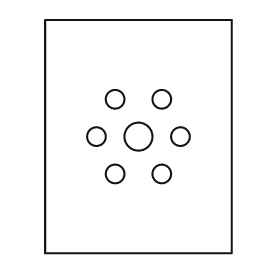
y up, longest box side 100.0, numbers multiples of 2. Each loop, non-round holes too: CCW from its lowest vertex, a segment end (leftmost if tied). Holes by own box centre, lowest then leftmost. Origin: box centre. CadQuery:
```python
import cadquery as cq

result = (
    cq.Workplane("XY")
    .moveTo(-40.0, -50.0)
    .lineTo(40.0, -50.0)
    .lineTo(40.0, 50.0)
    .lineTo(-40.0, 50.0)
    .close()
    .moveTo(-10.0, -16.0)
    .circle(4.0)
    .moveTo(10.0, -16.0)
    .circle(4.0)
    .moveTo(-18.0, 0.0)
    .circle(4.0)
    .moveTo(0.0, 0.0)
    .circle(6.0)
    .moveTo(18.0, 0.0)
    .circle(4.0)
    .moveTo(-10.0, 16.0)
    .circle(4.0)
    .moveTo(10.0, 16.0)
    .circle(4.0)
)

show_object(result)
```